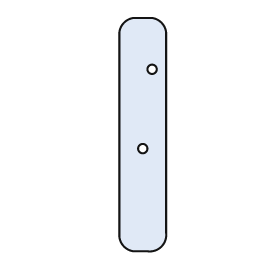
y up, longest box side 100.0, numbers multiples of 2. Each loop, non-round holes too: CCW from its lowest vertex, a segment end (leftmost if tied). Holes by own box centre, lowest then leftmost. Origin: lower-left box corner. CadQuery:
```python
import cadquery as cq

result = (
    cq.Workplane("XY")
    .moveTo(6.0, 0.0)
    .lineTo(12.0, 0.0)
    .threePointArc((18.0, 2.0), (20.0, 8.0))
    .lineTo(20.0, 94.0)
    .threePointArc((18.0, 98.0), (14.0, 100.0))
    .lineTo(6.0, 100.0)
    .threePointArc((2.0, 98.0), (0.0, 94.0))
    .lineTo(0.0, 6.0)
    .threePointArc((2.0, 2.0), (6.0, 0.0))
    .close()
    .moveTo(10.0, 44.0)
    .circle(2.0)
    .moveTo(14.0, 78.0)
    .circle(2.0)
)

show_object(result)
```